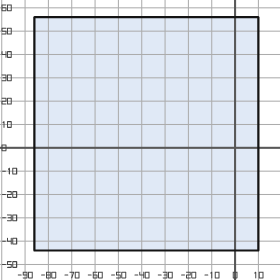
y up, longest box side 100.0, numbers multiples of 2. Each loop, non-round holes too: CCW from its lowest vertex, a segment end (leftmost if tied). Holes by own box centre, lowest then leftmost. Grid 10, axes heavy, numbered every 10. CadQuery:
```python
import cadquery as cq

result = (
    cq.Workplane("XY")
    .moveTo(-86.0, -44.0)
    .lineTo(10.0, -44.0)
    .lineTo(10.0, 56.0)
    .lineTo(-86.0, 56.0)
    .close()
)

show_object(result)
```